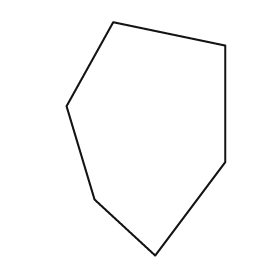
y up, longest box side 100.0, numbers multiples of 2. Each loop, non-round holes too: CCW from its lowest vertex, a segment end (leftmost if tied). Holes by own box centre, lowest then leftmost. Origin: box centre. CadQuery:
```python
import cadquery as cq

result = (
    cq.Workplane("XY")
    .moveTo(4.0, -50.0)
    .lineTo(34.0, -10.0)
    .lineTo(34.0, 40.0)
    .lineTo(-14.0, 50.0)
    .lineTo(-34.0, 14.0)
    .lineTo(-22.0, -26.0)
    .close()
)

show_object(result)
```